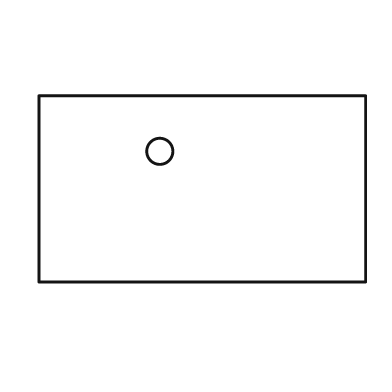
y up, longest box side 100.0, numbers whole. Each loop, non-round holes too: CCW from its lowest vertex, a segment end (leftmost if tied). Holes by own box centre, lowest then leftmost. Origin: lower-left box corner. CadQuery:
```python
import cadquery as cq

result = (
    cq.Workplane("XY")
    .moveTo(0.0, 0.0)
    .lineTo(100.0, 0.0)
    .lineTo(100.0, 57.0)
    .lineTo(0.0, 57.0)
    .close()
    .moveTo(37.0, 40.0)
    .circle(4.0)
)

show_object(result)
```